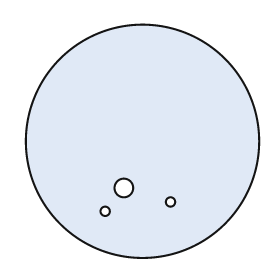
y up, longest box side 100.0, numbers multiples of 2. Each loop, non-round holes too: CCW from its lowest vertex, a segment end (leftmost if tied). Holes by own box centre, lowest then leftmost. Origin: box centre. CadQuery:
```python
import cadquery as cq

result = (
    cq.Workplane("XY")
    .moveTo(0.0, 0.0)
    .circle(50.0)
    .moveTo(-16.0, -30.0)
    .circle(2.0)
    .moveTo(12.0, -26.0)
    .circle(2.0)
    .moveTo(-8.0, -20.0)
    .circle(4.0)
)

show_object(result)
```